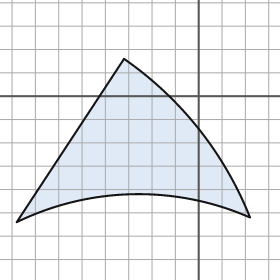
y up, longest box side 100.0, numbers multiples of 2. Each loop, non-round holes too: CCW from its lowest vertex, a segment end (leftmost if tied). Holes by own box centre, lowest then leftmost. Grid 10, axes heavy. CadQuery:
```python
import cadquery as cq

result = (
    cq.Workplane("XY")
    .moveTo(-78.0, -54.0)
    .threePointArc((-28.0, -42.0), (22.0, -52.0))
    .threePointArc((0.0, -14.0), (-32.0, 16.0))
    .close()
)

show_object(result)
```